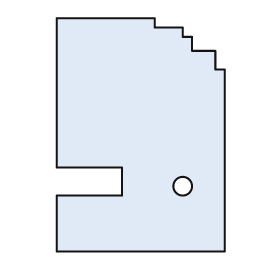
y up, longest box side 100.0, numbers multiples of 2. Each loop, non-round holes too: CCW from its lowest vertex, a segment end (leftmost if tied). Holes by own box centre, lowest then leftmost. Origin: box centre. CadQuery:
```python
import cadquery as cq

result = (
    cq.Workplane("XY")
    .moveTo(-36.0, -50.0)
    .lineTo(36.0, -50.0)
    .lineTo(36.0, 28.0)
    .lineTo(32.0, 28.0)
    .lineTo(32.0, 36.0)
    .lineTo(22.0, 36.0)
    .lineTo(22.0, 42.0)
    .lineTo(18.0, 42.0)
    .lineTo(18.0, 46.0)
    .lineTo(6.0, 46.0)
    .lineTo(6.0, 50.0)
    .lineTo(-36.0, 50.0)
    .lineTo(-36.0, -14.0)
    .lineTo(-8.0, -14.0)
    .lineTo(-8.0, -26.0)
    .lineTo(-36.0, -26.0)
    .close()
    .moveTo(18.0, -22.0)
    .circle(4.0)
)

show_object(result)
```